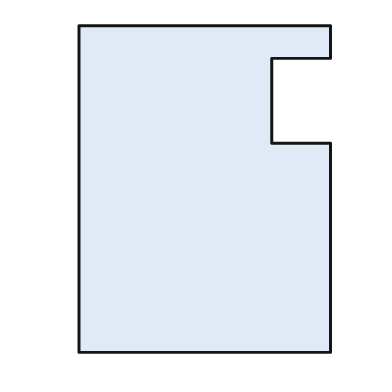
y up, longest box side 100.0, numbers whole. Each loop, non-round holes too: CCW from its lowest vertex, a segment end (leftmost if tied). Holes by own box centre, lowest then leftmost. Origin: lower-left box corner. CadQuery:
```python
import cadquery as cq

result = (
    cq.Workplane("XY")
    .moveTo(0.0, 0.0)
    .lineTo(77.0, 0.0)
    .lineTo(77.0, 64.0)
    .lineTo(59.0, 64.0)
    .lineTo(59.0, 90.0)
    .lineTo(77.0, 90.0)
    .lineTo(77.0, 100.0)
    .lineTo(0.0, 100.0)
    .close()
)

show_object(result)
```